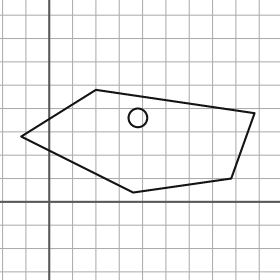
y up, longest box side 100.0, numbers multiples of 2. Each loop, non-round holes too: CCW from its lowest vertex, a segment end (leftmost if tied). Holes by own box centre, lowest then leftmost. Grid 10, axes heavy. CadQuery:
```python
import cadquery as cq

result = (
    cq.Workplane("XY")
    .moveTo(36.0, 4.0)
    .lineTo(78.0, 10.0)
    .lineTo(88.0, 38.0)
    .lineTo(20.0, 48.0)
    .lineTo(-12.0, 28.0)
    .close()
    .moveTo(38.0, 36.0)
    .circle(4.0)
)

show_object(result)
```